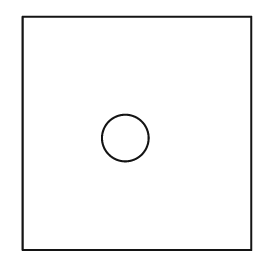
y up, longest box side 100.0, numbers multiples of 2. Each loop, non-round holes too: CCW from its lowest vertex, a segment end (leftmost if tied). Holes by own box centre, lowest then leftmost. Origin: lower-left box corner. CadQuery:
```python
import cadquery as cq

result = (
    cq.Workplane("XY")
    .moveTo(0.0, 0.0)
    .lineTo(98.0, 0.0)
    .lineTo(98.0, 100.0)
    .lineTo(0.0, 100.0)
    .close()
    .moveTo(44.0, 48.0)
    .circle(10.0)
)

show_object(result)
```